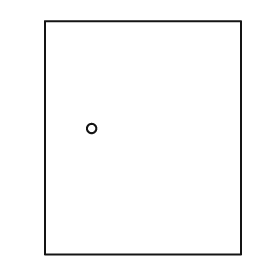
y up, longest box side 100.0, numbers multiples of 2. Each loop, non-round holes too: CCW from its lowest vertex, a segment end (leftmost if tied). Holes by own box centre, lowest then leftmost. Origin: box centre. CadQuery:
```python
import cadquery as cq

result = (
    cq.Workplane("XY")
    .moveTo(-42.0, -50.0)
    .lineTo(42.0, -50.0)
    .lineTo(42.0, 50.0)
    .lineTo(-42.0, 50.0)
    .close()
    .moveTo(-22.0, 4.0)
    .circle(2.0)
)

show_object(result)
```